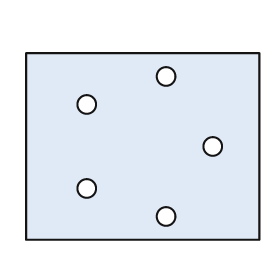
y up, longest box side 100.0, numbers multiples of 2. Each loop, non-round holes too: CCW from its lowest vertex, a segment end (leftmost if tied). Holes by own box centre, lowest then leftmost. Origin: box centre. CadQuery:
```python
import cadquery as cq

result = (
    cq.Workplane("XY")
    .moveTo(-50.0, -40.0)
    .lineTo(50.0, -40.0)
    .lineTo(50.0, 40.0)
    .lineTo(-50.0, 40.0)
    .close()
    .moveTo(10.0, -30.0)
    .circle(4.0)
    .moveTo(-24.0, -18.0)
    .circle(4.0)
    .moveTo(30.0, 0.0)
    .circle(4.0)
    .moveTo(-24.0, 18.0)
    .circle(4.0)
    .moveTo(10.0, 30.0)
    .circle(4.0)
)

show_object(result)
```